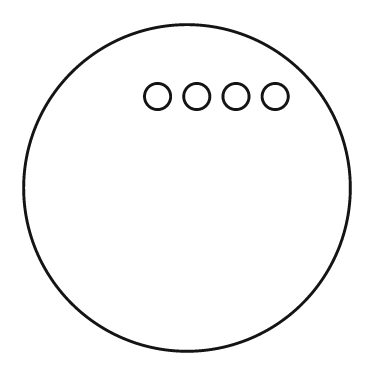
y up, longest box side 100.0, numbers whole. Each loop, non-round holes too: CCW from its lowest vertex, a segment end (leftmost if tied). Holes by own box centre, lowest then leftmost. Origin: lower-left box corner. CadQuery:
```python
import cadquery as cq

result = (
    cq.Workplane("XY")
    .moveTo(50.0, 50.0)
    .circle(50.0)
    .moveTo(41.0, 78.0)
    .circle(4.0)
    .moveTo(53.0, 78.0)
    .circle(4.0)
    .moveTo(65.0, 78.0)
    .circle(4.0)
    .moveTo(77.0, 78.0)
    .circle(4.0)
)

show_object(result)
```